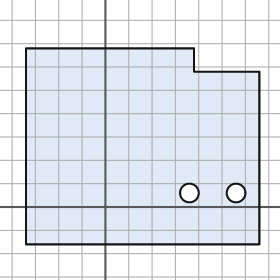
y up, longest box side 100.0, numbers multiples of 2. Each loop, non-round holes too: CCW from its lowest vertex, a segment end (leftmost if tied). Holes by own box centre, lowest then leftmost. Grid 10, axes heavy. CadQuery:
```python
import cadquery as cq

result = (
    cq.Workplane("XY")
    .moveTo(-34.0, -16.0)
    .lineTo(66.0, -16.0)
    .lineTo(66.0, 58.0)
    .lineTo(38.0, 58.0)
    .lineTo(38.0, 68.0)
    .lineTo(-34.0, 68.0)
    .close()
    .moveTo(36.0, 6.0)
    .circle(4.0)
    .moveTo(56.0, 6.0)
    .circle(4.0)
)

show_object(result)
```